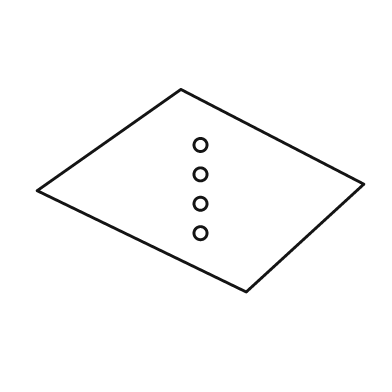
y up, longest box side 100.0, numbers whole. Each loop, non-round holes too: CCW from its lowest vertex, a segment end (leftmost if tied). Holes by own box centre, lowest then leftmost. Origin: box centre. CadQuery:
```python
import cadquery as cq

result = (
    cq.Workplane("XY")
    .moveTo(14.0, -31.0)
    .lineTo(50.0, 2.0)
    .lineTo(-6.0, 31.0)
    .lineTo(-50.0, 0.0)
    .close()
    .moveTo(0.0, -13.0)
    .circle(2.0)
    .moveTo(0.0, -4.0)
    .circle(2.0)
    .moveTo(0.0, 5.0)
    .circle(2.0)
    .moveTo(0.0, 14.0)
    .circle(2.0)
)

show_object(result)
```